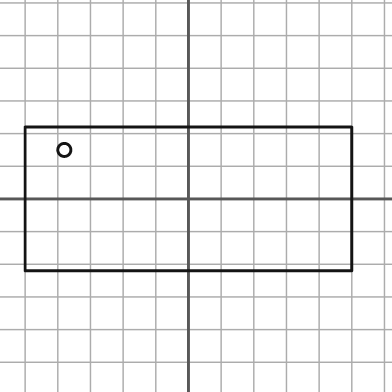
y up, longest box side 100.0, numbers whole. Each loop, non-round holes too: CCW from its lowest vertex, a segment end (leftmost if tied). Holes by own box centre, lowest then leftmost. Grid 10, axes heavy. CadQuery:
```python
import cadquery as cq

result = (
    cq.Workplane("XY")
    .moveTo(-50.0, -22.0)
    .lineTo(50.0, -22.0)
    .lineTo(50.0, 22.0)
    .lineTo(-50.0, 22.0)
    .close()
    .moveTo(-38.0, 15.0)
    .circle(2.0)
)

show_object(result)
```